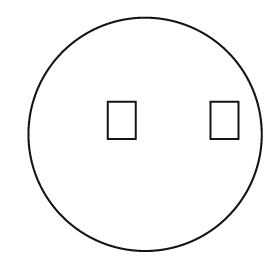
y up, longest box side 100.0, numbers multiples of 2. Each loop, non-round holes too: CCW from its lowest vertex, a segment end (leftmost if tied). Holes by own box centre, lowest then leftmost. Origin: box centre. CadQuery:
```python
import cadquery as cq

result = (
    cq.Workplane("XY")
    .moveTo(0.0, 0.0)
    .circle(50.0)
    .moveTo(-16.0, -2.0)
    .lineTo(-4.0, -2.0)
    .lineTo(-4.0, 14.0)
    .lineTo(-16.0, 14.0)
    .close()
    .moveTo(28.0, -2.0)
    .lineTo(40.0, -2.0)
    .lineTo(40.0, 14.0)
    .lineTo(28.0, 14.0)
    .close()
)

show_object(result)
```